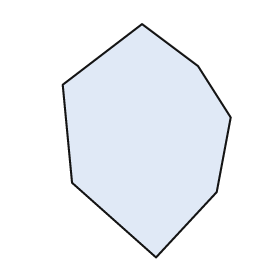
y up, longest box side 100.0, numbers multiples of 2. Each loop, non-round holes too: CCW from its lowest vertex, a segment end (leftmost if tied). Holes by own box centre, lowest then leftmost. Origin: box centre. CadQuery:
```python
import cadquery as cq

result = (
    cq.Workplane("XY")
    .moveTo(4.0, -50.0)
    .lineTo(30.0, -22.0)
    .lineTo(36.0, 10.0)
    .lineTo(22.0, 32.0)
    .lineTo(-2.0, 50.0)
    .lineTo(-36.0, 24.0)
    .lineTo(-32.0, -18.0)
    .close()
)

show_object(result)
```